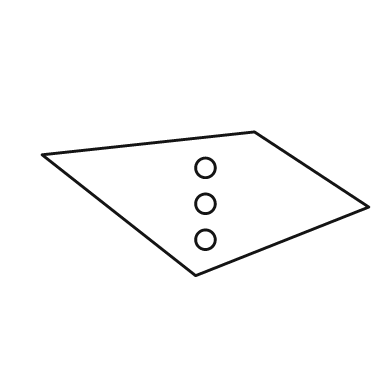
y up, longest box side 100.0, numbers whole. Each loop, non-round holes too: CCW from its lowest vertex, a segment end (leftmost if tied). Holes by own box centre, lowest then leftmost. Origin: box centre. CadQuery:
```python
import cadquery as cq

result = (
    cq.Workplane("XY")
    .moveTo(-3.0, -22.0)
    .lineTo(50.0, -1.0)
    .lineTo(15.0, 22.0)
    .lineTo(-50.0, 15.0)
    .close()
    .moveTo(0.0, -11.0)
    .circle(3.0)
    .moveTo(0.0, 0.0)
    .circle(3.0)
    .moveTo(0.0, 11.0)
    .circle(3.0)
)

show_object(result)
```